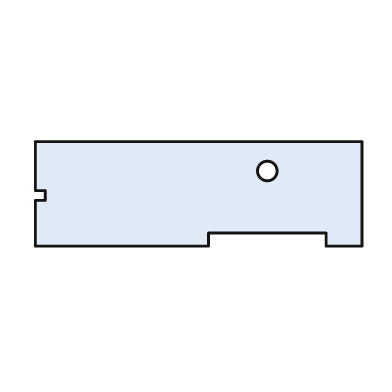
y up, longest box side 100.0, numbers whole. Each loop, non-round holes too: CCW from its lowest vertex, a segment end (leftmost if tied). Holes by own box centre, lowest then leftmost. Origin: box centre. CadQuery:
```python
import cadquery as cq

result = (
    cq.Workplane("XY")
    .moveTo(-50.0, -16.0)
    .lineTo(3.0, -16.0)
    .lineTo(3.0, -12.0)
    .lineTo(39.0, -12.0)
    .lineTo(39.0, -16.0)
    .lineTo(50.0, -16.0)
    .lineTo(50.0, 16.0)
    .lineTo(-50.0, 16.0)
    .lineTo(-50.0, 1.0)
    .lineTo(-47.0, 1.0)
    .lineTo(-47.0, -2.0)
    .lineTo(-50.0, -2.0)
    .close()
    .moveTo(21.0, 7.0)
    .circle(3.0)
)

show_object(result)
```